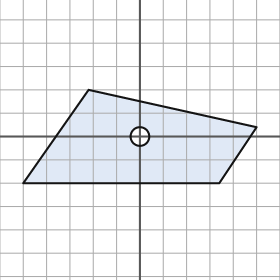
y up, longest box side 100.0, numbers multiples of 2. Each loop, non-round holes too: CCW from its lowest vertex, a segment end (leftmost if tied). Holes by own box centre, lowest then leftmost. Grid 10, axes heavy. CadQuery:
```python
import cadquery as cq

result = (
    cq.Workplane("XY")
    .moveTo(-50.0, -20.0)
    .lineTo(34.0, -20.0)
    .lineTo(50.0, 4.0)
    .lineTo(-22.0, 20.0)
    .close()
    .moveTo(0.0, 0.0)
    .circle(4.0)
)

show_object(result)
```